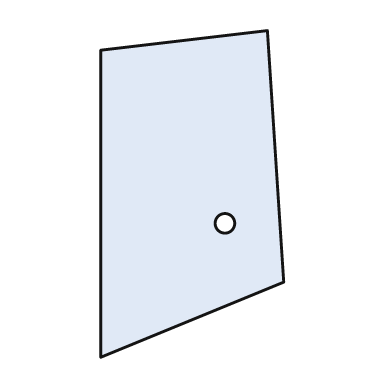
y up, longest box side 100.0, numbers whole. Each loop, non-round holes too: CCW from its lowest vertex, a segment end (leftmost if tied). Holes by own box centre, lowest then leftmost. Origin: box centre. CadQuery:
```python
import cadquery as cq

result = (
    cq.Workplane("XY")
    .moveTo(-28.0, -50.0)
    .lineTo(28.0, -27.0)
    .lineTo(23.0, 50.0)
    .lineTo(-28.0, 44.0)
    .close()
    .moveTo(10.0, -9.0)
    .circle(3.0)
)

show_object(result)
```